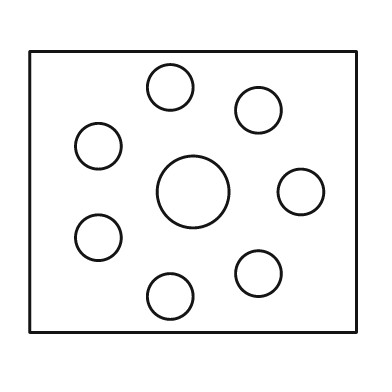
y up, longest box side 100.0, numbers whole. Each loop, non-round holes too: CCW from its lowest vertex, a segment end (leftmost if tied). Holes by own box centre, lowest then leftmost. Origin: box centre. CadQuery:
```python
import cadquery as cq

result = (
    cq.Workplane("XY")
    .moveTo(-50.0, -43.0)
    .lineTo(50.0, -43.0)
    .lineTo(50.0, 43.0)
    .lineTo(-50.0, 43.0)
    .close()
    .moveTo(-7.0, -32.0)
    .circle(7.0)
    .moveTo(20.0, -25.0)
    .circle(7.0)
    .moveTo(-29.0, -14.0)
    .circle(7.0)
    .moveTo(0.0, 0.0)
    .circle(11.0)
    .moveTo(33.0, 0.0)
    .circle(7.0)
    .moveTo(-29.0, 14.0)
    .circle(7.0)
    .moveTo(20.0, 25.0)
    .circle(7.0)
    .moveTo(-7.0, 32.0)
    .circle(7.0)
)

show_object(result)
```